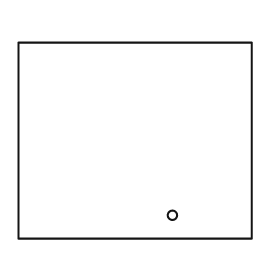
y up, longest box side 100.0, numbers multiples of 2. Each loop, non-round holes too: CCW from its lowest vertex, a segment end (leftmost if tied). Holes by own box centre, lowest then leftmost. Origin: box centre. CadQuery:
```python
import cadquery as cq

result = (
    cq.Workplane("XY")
    .moveTo(-50.0, -42.0)
    .lineTo(50.0, -42.0)
    .lineTo(50.0, 42.0)
    .lineTo(-50.0, 42.0)
    .close()
    .moveTo(16.0, -32.0)
    .circle(2.0)
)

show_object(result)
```